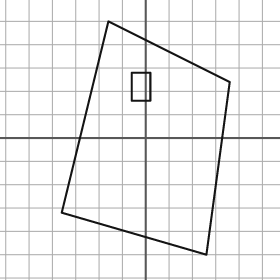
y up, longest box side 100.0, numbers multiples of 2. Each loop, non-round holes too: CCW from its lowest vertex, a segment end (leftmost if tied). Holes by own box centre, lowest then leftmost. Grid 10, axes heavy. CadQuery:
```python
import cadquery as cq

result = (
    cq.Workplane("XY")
    .moveTo(26.0, -50.0)
    .lineTo(36.0, 24.0)
    .lineTo(-16.0, 50.0)
    .lineTo(-36.0, -32.0)
    .close()
    .moveTo(-6.0, 16.0)
    .lineTo(2.0, 16.0)
    .lineTo(2.0, 28.0)
    .lineTo(-6.0, 28.0)
    .close()
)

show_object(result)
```